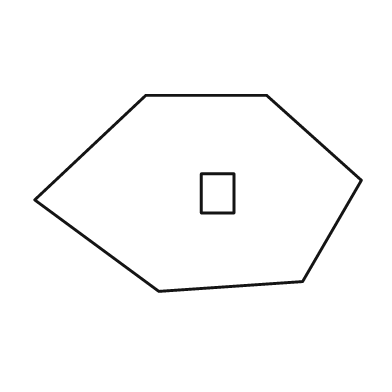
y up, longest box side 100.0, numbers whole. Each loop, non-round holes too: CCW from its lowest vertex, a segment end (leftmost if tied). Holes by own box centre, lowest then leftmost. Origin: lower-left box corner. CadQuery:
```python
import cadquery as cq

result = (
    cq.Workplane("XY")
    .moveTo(38.0, 0.0)
    .lineTo(82.0, 3.0)
    .lineTo(100.0, 34.0)
    .lineTo(71.0, 60.0)
    .lineTo(34.0, 60.0)
    .lineTo(0.0, 28.0)
    .close()
    .moveTo(51.0, 24.0)
    .lineTo(61.0, 24.0)
    .lineTo(61.0, 36.0)
    .lineTo(51.0, 36.0)
    .close()
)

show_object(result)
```